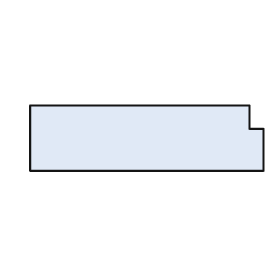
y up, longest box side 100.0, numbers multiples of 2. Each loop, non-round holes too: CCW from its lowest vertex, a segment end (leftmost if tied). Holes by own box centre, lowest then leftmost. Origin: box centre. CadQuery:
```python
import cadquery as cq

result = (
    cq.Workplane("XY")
    .moveTo(-50.0, -14.0)
    .lineTo(50.0, -14.0)
    .lineTo(50.0, 4.0)
    .lineTo(44.0, 4.0)
    .lineTo(44.0, 14.0)
    .lineTo(-50.0, 14.0)
    .close()
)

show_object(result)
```